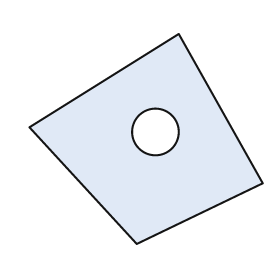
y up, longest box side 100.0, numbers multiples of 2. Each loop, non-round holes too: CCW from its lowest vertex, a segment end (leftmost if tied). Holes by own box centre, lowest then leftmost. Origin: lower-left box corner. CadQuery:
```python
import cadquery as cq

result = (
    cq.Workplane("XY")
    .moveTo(46.0, 0.0)
    .lineTo(100.0, 26.0)
    .lineTo(64.0, 90.0)
    .lineTo(0.0, 50.0)
    .close()
    .moveTo(54.0, 48.0)
    .circle(10.0)
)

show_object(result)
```